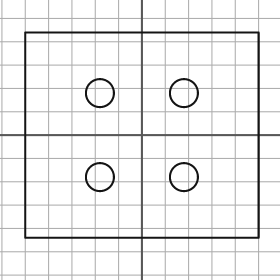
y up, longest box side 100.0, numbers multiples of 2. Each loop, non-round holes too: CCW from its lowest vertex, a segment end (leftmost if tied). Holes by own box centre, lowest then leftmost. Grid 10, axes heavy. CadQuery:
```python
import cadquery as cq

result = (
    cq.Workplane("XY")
    .moveTo(-50.0, -44.0)
    .lineTo(50.0, -44.0)
    .lineTo(50.0, 44.0)
    .lineTo(-50.0, 44.0)
    .close()
    .moveTo(-18.0, -18.0)
    .circle(6.0)
    .moveTo(18.0, -18.0)
    .circle(6.0)
    .moveTo(-18.0, 18.0)
    .circle(6.0)
    .moveTo(18.0, 18.0)
    .circle(6.0)
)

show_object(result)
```